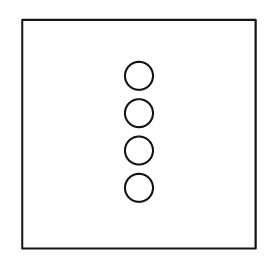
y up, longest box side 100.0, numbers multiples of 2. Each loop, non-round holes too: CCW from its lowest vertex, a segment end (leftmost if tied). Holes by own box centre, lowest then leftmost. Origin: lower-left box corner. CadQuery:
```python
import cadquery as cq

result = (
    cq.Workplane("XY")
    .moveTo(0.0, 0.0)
    .lineTo(100.0, 0.0)
    .lineTo(100.0, 98.0)
    .lineTo(0.0, 98.0)
    .close()
    .moveTo(50.0, 26.0)
    .circle(6.0)
    .moveTo(50.0, 42.0)
    .circle(6.0)
    .moveTo(50.0, 58.0)
    .circle(6.0)
    .moveTo(50.0, 74.0)
    .circle(6.0)
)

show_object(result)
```